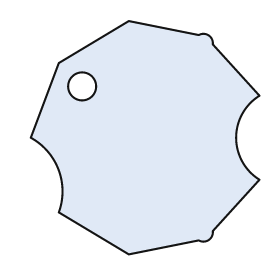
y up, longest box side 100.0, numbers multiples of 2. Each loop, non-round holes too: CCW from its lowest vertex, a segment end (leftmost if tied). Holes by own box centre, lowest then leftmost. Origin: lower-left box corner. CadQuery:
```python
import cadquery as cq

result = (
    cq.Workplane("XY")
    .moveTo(42.0, 0.0)
    .lineTo(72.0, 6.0)
    .threePointArc((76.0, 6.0), (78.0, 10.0))
    .lineTo(98.0, 32.0)
    .threePointArc((88.0, 50.0), (98.0, 68.0))
    .lineTo(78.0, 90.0)
    .threePointArc((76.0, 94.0), (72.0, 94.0))
    .lineTo(42.0, 100.0)
    .lineTo(12.0, 82.0)
    .lineTo(0.0, 50.0)
    .threePointArc((12.0, 36.0), (12.0, 18.0))
    .close()
    .moveTo(22.0, 72.0)
    .circle(6.0)
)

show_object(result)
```